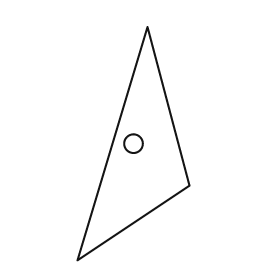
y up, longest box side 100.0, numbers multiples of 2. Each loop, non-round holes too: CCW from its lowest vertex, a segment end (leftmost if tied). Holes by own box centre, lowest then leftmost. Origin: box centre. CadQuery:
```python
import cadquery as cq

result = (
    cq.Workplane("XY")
    .moveTo(-24.0, -50.0)
    .lineTo(24.0, -18.0)
    .lineTo(6.0, 50.0)
    .close()
    .moveTo(0.0, 0.0)
    .circle(4.0)
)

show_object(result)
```